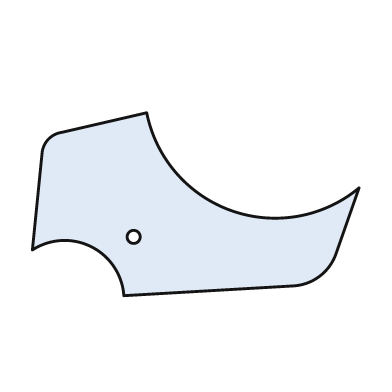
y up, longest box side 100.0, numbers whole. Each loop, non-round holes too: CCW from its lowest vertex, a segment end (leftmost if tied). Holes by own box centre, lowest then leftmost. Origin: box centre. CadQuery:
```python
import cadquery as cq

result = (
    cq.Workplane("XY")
    .moveTo(-22.0, -28.0)
    .lineTo(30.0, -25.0)
    .threePointArc((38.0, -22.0), (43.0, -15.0))
    .lineTo(50.0, 5.0)
    .threePointArc((11.0, -2.0), (-15.0, 28.0))
    .lineTo(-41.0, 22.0)
    .threePointArc((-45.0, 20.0), (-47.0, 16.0))
    .lineTo(-50.0, -14.0)
    .threePointArc((-32.0, -13.0), (-22.0, -28.0))
    .close()
    .moveTo(-19.0, -10.0)
    .circle(2.0)
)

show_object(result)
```